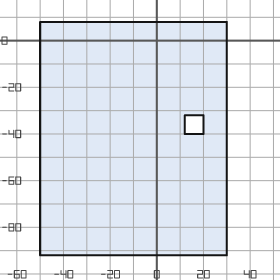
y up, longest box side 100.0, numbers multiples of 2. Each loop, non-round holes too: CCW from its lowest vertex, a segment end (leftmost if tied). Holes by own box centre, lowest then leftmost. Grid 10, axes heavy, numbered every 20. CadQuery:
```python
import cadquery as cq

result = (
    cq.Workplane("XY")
    .moveTo(-50.0, -92.0)
    .lineTo(30.0, -92.0)
    .lineTo(30.0, 8.0)
    .lineTo(-50.0, 8.0)
    .close()
    .moveTo(12.0, -40.0)
    .lineTo(20.0, -40.0)
    .lineTo(20.0, -32.0)
    .lineTo(12.0, -32.0)
    .close()
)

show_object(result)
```